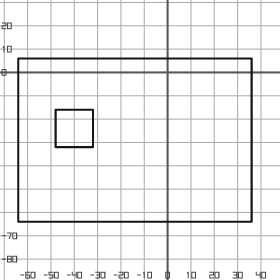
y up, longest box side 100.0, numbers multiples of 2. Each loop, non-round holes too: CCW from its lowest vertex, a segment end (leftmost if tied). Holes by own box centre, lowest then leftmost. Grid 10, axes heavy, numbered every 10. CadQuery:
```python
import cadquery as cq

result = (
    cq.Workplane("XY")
    .moveTo(-64.0, -64.0)
    .lineTo(36.0, -64.0)
    .lineTo(36.0, 6.0)
    .lineTo(-64.0, 6.0)
    .close()
    .moveTo(-48.0, -32.0)
    .lineTo(-32.0, -32.0)
    .lineTo(-32.0, -16.0)
    .lineTo(-48.0, -16.0)
    .close()
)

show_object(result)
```